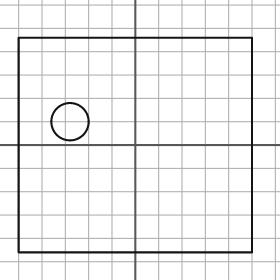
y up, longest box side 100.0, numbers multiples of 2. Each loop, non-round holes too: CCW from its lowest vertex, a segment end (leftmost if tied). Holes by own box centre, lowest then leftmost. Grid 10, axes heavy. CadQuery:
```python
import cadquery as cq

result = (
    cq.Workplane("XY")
    .moveTo(-50.0, -46.0)
    .lineTo(50.0, -46.0)
    .lineTo(50.0, 46.0)
    .lineTo(-50.0, 46.0)
    .close()
    .moveTo(-28.0, 10.0)
    .circle(8.0)
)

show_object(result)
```